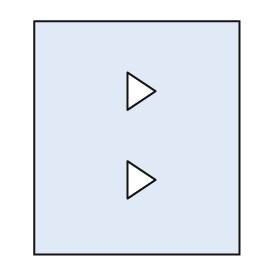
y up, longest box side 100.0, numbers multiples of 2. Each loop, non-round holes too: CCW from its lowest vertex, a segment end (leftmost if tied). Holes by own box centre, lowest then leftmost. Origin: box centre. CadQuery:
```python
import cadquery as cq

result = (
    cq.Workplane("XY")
    .moveTo(-44.0, -50.0)
    .lineTo(44.0, -50.0)
    .lineTo(44.0, 50.0)
    .lineTo(-44.0, 50.0)
    .close()
    .moveTo(-4.0, -26.0)
    .lineTo(8.0, -18.0)
    .lineTo(-4.0, -10.0)
    .close()
    .moveTo(-4.0, 12.0)
    .lineTo(8.0, 20.0)
    .lineTo(-4.0, 28.0)
    .close()
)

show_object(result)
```